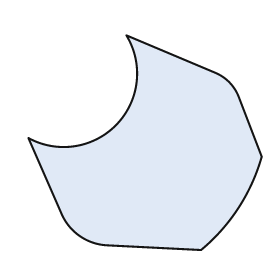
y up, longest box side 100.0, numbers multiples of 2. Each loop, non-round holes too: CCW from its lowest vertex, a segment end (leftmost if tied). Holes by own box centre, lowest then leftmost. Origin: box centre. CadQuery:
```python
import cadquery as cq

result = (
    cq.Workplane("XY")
    .moveTo(24.0, -46.0)
    .threePointArc((40.0, -28.0), (50.0, -6.0))
    .lineTo(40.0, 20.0)
    .threePointArc((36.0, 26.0), (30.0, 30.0))
    .lineTo(-8.0, 46.0)
    .threePointArc((-12.0, 8.0), (-50.0, 2.0))
    .lineTo(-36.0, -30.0)
    .threePointArc((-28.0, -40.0), (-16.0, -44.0))
    .close()
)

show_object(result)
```